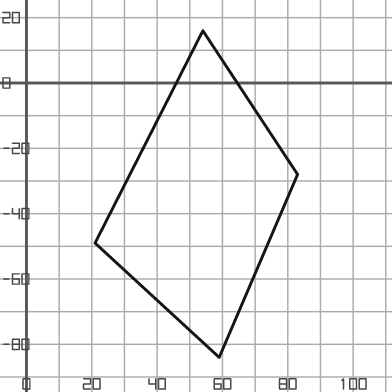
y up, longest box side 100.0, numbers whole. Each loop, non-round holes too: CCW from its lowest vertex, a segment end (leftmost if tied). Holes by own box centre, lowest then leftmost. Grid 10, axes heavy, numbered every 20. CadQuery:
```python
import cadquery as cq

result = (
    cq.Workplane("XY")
    .moveTo(59.0, -84.0)
    .lineTo(83.0, -28.0)
    .lineTo(54.0, 16.0)
    .lineTo(21.0, -49.0)
    .close()
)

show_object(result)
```